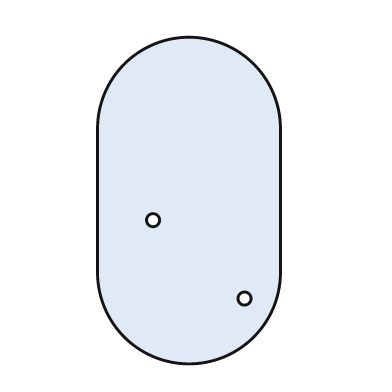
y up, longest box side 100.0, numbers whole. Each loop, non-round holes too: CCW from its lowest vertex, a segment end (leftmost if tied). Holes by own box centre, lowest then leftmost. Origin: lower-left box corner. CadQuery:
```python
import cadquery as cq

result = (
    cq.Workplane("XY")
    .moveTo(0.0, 28.0)
    .threePointArc((28.0, 0.0), (56.0, 28.0))
    .lineTo(56.0, 72.0)
    .threePointArc((28.0, 100.0), (0.0, 72.0))
    .close()
    .moveTo(45.0, 20.0)
    .circle(2.0)
    .moveTo(17.0, 44.0)
    .circle(2.0)
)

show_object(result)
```